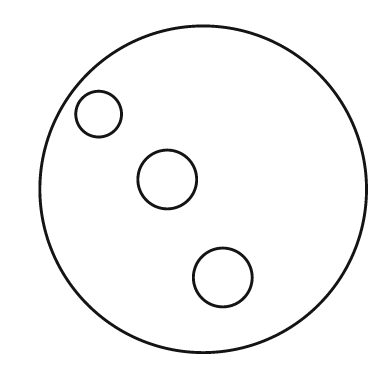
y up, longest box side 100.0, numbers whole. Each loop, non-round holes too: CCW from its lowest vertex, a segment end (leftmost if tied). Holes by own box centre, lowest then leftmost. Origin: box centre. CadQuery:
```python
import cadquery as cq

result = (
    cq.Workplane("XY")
    .moveTo(0.0, 0.0)
    .circle(50.0)
    .moveTo(6.0, -27.0)
    .circle(9.0)
    .moveTo(-11.0, 3.0)
    .circle(9.0)
    .moveTo(-32.0, 23.0)
    .circle(7.0)
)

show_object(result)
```